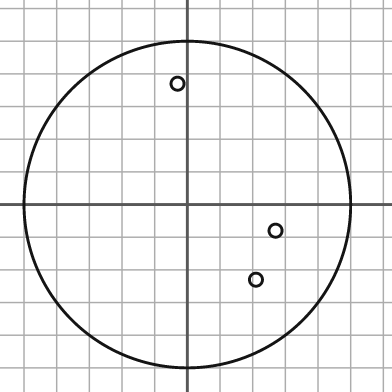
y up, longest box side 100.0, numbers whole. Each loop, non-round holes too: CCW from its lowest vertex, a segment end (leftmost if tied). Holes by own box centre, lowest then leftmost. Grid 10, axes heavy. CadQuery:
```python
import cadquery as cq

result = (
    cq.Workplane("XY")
    .moveTo(0.0, 0.0)
    .circle(50.0)
    .moveTo(21.0, -23.0)
    .circle(2.0)
    .moveTo(27.0, -8.0)
    .circle(2.0)
    .moveTo(-3.0, 37.0)
    .circle(2.0)
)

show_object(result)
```